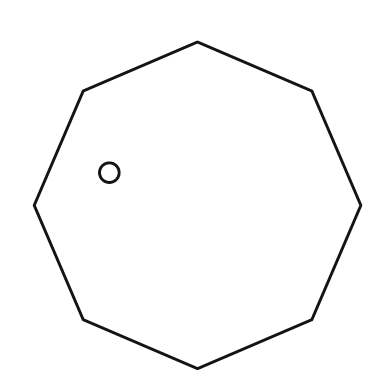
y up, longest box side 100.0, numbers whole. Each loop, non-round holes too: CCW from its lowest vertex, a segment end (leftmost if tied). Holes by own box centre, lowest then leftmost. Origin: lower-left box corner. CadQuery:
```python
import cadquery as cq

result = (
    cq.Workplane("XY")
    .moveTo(50.0, 0.0)
    .lineTo(85.0, 15.0)
    .lineTo(100.0, 50.0)
    .lineTo(85.0, 85.0)
    .lineTo(50.0, 100.0)
    .lineTo(15.0, 85.0)
    .lineTo(0.0, 50.0)
    .lineTo(15.0, 15.0)
    .close()
    .moveTo(23.0, 60.0)
    .circle(3.0)
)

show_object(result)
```